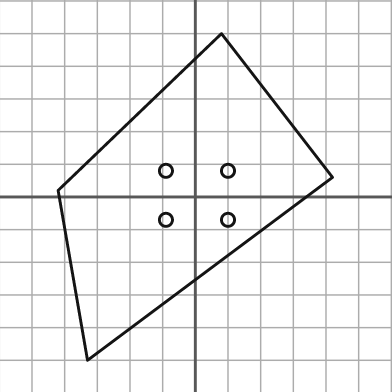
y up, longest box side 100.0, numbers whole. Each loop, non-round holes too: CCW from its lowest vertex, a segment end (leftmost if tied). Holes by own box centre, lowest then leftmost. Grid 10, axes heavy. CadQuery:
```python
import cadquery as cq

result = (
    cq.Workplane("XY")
    .moveTo(-33.0, -50.0)
    .lineTo(42.0, 6.0)
    .lineTo(8.0, 50.0)
    .lineTo(-42.0, 2.0)
    .close()
    .moveTo(-9.0, -7.0)
    .circle(2.0)
    .moveTo(10.0, -7.0)
    .circle(2.0)
    .moveTo(-9.0, 8.0)
    .circle(2.0)
    .moveTo(10.0, 8.0)
    .circle(2.0)
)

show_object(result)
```